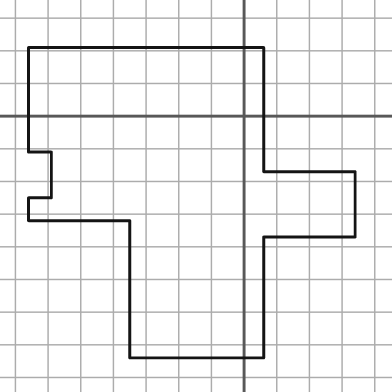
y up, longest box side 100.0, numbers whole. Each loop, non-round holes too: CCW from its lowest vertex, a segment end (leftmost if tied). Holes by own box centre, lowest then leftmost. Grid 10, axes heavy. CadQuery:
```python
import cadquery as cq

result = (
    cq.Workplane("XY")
    .moveTo(-35.0, -74.0)
    .lineTo(6.0, -74.0)
    .lineTo(6.0, -37.0)
    .lineTo(34.0, -37.0)
    .lineTo(34.0, -17.0)
    .lineTo(6.0, -17.0)
    .lineTo(6.0, 21.0)
    .lineTo(-66.0, 21.0)
    .lineTo(-66.0, -11.0)
    .lineTo(-59.0, -11.0)
    .lineTo(-59.0, -25.0)
    .lineTo(-66.0, -25.0)
    .lineTo(-66.0, -32.0)
    .lineTo(-35.0, -32.0)
    .close()
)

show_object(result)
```